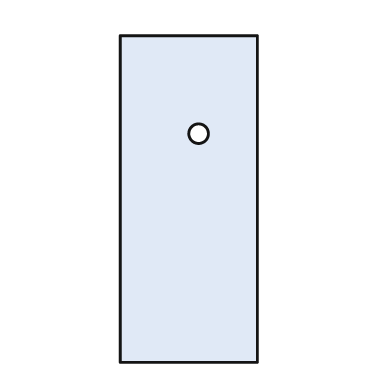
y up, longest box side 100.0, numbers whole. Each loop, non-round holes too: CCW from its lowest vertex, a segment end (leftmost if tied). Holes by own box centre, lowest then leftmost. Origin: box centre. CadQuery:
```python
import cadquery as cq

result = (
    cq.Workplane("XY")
    .moveTo(-21.0, -50.0)
    .lineTo(21.0, -50.0)
    .lineTo(21.0, 50.0)
    .lineTo(-21.0, 50.0)
    .close()
    .moveTo(3.0, 20.0)
    .circle(3.0)
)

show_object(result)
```